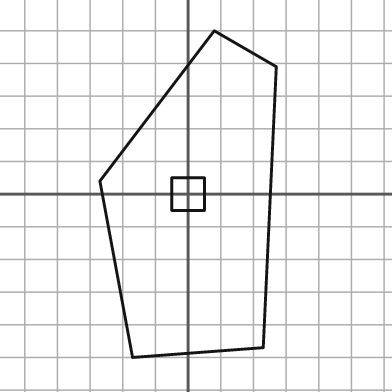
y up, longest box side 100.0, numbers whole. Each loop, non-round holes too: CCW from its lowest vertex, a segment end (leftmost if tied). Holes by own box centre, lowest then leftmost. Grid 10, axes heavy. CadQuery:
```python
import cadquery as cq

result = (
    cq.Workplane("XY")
    .moveTo(-17.0, -50.0)
    .lineTo(23.0, -47.0)
    .lineTo(27.0, 39.0)
    .lineTo(8.0, 50.0)
    .lineTo(-27.0, 4.0)
    .close()
    .moveTo(-5.0, -5.0)
    .lineTo(5.0, -5.0)
    .lineTo(5.0, 5.0)
    .lineTo(-5.0, 5.0)
    .close()
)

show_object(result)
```